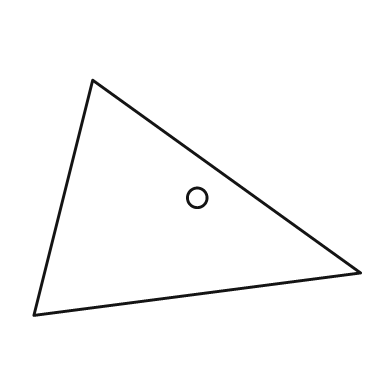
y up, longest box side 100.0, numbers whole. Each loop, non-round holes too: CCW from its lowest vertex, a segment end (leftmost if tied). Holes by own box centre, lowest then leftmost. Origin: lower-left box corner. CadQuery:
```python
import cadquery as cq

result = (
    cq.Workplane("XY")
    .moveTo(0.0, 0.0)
    .lineTo(100.0, 13.0)
    .lineTo(18.0, 72.0)
    .close()
    .moveTo(50.0, 36.0)
    .circle(3.0)
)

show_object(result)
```